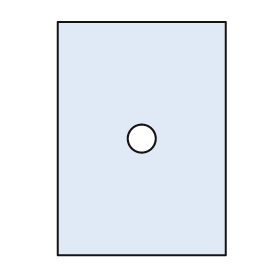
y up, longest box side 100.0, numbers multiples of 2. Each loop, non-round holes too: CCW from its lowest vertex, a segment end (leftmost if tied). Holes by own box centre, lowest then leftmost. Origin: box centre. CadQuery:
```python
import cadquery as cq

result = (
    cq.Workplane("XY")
    .moveTo(-36.0, -50.0)
    .lineTo(36.0, -50.0)
    .lineTo(36.0, 50.0)
    .lineTo(-36.0, 50.0)
    .close()
    .moveTo(0.0, 0.0)
    .circle(6.0)
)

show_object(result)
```